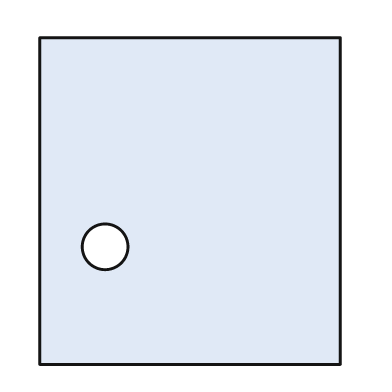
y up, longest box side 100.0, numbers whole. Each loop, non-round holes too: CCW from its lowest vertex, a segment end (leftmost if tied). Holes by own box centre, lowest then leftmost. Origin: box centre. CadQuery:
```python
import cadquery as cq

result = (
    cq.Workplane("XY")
    .moveTo(-46.0, -50.0)
    .lineTo(46.0, -50.0)
    .lineTo(46.0, 50.0)
    .lineTo(-46.0, 50.0)
    .close()
    .moveTo(-26.0, -14.0)
    .circle(7.0)
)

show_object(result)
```